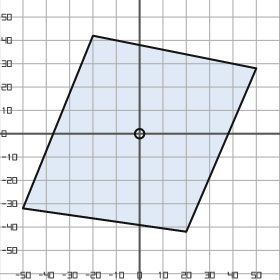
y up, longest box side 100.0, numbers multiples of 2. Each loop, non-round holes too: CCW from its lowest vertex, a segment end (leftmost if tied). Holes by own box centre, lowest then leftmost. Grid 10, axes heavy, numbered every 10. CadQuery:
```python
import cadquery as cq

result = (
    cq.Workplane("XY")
    .moveTo(20.0, -42.0)
    .lineTo(50.0, 28.0)
    .lineTo(-20.0, 42.0)
    .lineTo(-50.0, -32.0)
    .close()
    .moveTo(0.0, 0.0)
    .circle(2.0)
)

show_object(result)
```